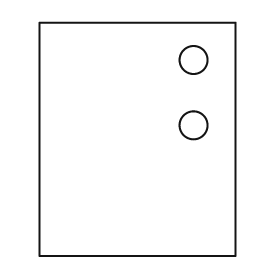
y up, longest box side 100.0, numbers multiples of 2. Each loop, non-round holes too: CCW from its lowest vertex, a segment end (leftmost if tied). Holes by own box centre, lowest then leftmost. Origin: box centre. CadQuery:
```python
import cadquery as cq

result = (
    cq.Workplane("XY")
    .moveTo(-42.0, -50.0)
    .lineTo(42.0, -50.0)
    .lineTo(42.0, 50.0)
    .lineTo(-42.0, 50.0)
    .close()
    .moveTo(24.0, 6.0)
    .circle(6.0)
    .moveTo(24.0, 34.0)
    .circle(6.0)
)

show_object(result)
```